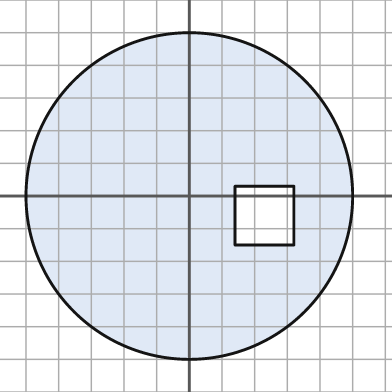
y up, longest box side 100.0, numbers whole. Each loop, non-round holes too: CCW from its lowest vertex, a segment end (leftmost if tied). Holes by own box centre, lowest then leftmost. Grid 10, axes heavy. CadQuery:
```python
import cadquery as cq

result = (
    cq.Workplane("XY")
    .moveTo(0.0, 0.0)
    .circle(50.0)
    .moveTo(14.0, -15.0)
    .lineTo(32.0, -15.0)
    .lineTo(32.0, 3.0)
    .lineTo(14.0, 3.0)
    .close()
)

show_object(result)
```